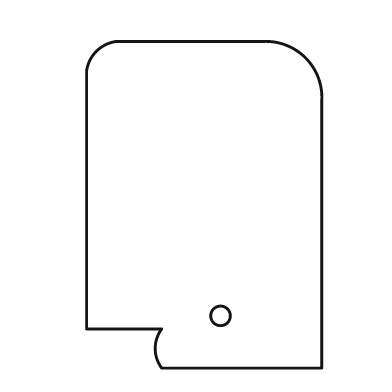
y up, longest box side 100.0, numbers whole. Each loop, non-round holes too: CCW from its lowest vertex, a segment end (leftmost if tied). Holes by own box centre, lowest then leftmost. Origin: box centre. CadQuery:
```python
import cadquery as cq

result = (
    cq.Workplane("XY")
    .moveTo(-13.0, -50.0)
    .lineTo(36.0, -50.0)
    .lineTo(36.0, 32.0)
    .threePointArc((31.0, 45.0), (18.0, 50.0))
    .lineTo(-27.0, 50.0)
    .threePointArc((-33.0, 47.0), (-36.0, 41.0))
    .lineTo(-36.0, -38.0)
    .lineTo(-13.0, -38.0)
    .threePointArc((-15.0, -44.0), (-13.0, -50.0))
    .close()
    .moveTo(5.0, -34.0)
    .circle(3.0)
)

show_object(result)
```